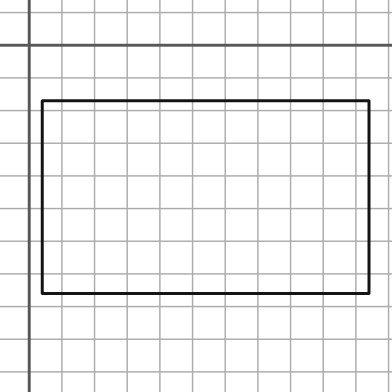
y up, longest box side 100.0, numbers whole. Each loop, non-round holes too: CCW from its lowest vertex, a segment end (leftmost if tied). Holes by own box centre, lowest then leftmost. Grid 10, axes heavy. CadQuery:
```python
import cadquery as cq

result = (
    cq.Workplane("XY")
    .moveTo(4.0, -76.0)
    .lineTo(104.0, -76.0)
    .lineTo(104.0, -17.0)
    .lineTo(4.0, -17.0)
    .close()
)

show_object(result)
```